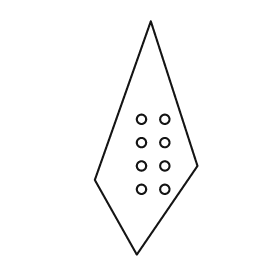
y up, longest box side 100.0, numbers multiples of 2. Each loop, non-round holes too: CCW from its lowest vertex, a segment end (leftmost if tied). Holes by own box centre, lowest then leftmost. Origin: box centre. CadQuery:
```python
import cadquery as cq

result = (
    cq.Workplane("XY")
    .moveTo(-4.0, -50.0)
    .lineTo(22.0, -12.0)
    .lineTo(2.0, 50.0)
    .lineTo(-22.0, -18.0)
    .close()
    .moveTo(-2.0, -22.0)
    .circle(2.0)
    .moveTo(8.0, -22.0)
    .circle(2.0)
    .moveTo(-2.0, -12.0)
    .circle(2.0)
    .moveTo(8.0, -12.0)
    .circle(2.0)
    .moveTo(-2.0, -2.0)
    .circle(2.0)
    .moveTo(8.0, -2.0)
    .circle(2.0)
    .moveTo(-2.0, 8.0)
    .circle(2.0)
    .moveTo(8.0, 8.0)
    .circle(2.0)
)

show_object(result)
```